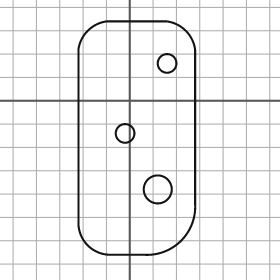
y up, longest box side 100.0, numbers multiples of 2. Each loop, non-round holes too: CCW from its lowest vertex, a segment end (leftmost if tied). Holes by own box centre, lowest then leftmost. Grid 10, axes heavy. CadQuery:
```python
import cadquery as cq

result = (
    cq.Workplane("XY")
    .moveTo(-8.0, -66.0)
    .lineTo(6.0, -66.0)
    .threePointArc((22.0, -60.0), (28.0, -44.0))
    .lineTo(28.0, 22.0)
    .threePointArc((24.0, 30.0), (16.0, 34.0))
    .lineTo(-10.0, 34.0)
    .threePointArc((-18.0, 30.0), (-22.0, 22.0))
    .lineTo(-22.0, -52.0)
    .threePointArc((-18.0, -62.0), (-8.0, -66.0))
    .close()
    .moveTo(12.0, -38.0)
    .circle(6.0)
    .moveTo(-2.0, -14.0)
    .circle(4.0)
    .moveTo(16.0, 16.0)
    .circle(4.0)
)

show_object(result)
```